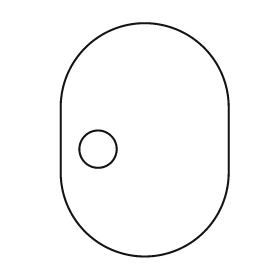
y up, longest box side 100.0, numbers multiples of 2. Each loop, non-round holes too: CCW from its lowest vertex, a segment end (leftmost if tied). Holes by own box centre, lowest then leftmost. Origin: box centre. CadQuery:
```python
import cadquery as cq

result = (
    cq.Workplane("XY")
    .moveTo(-36.0, -14.0)
    .threePointArc((0.0, -50.0), (36.0, -14.0))
    .lineTo(36.0, 14.0)
    .threePointArc((0.0, 50.0), (-36.0, 14.0))
    .close()
    .moveTo(-20.0, -4.0)
    .circle(8.0)
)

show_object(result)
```